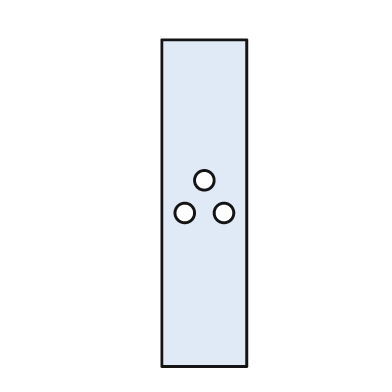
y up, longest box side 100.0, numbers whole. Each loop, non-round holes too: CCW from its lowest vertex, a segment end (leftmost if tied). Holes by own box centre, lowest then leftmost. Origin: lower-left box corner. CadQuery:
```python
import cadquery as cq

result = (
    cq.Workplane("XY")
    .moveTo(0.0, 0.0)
    .lineTo(26.0, 0.0)
    .lineTo(26.0, 100.0)
    .lineTo(0.0, 100.0)
    .close()
    .moveTo(7.0, 47.0)
    .circle(3.0)
    .moveTo(19.0, 47.0)
    .circle(3.0)
    .moveTo(13.0, 57.0)
    .circle(3.0)
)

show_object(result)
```